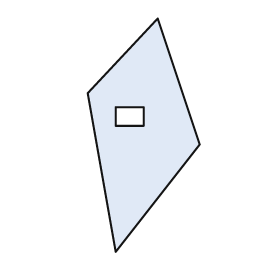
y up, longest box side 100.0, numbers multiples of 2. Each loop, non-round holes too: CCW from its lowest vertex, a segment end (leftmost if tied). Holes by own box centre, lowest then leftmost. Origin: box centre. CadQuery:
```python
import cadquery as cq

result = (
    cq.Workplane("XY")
    .moveTo(-12.0, -50.0)
    .lineTo(24.0, -4.0)
    .lineTo(6.0, 50.0)
    .lineTo(-24.0, 18.0)
    .close()
    .moveTo(-12.0, 4.0)
    .lineTo(0.0, 4.0)
    .lineTo(0.0, 12.0)
    .lineTo(-12.0, 12.0)
    .close()
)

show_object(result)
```